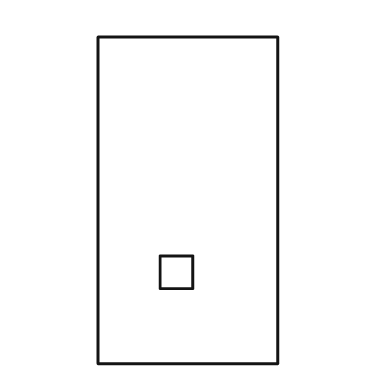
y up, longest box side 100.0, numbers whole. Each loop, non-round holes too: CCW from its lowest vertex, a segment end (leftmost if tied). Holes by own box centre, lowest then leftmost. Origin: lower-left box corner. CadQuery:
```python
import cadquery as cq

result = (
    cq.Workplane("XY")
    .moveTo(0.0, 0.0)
    .lineTo(55.0, 0.0)
    .lineTo(55.0, 100.0)
    .lineTo(0.0, 100.0)
    .close()
    .moveTo(19.0, 23.0)
    .lineTo(29.0, 23.0)
    .lineTo(29.0, 33.0)
    .lineTo(19.0, 33.0)
    .close()
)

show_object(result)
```